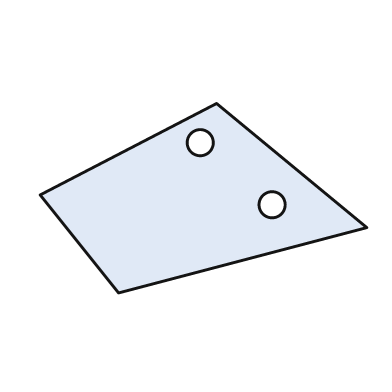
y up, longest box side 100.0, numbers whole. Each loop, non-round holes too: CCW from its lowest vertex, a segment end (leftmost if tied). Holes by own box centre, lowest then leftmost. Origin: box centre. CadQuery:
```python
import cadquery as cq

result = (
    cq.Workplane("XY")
    .moveTo(-26.0, -29.0)
    .lineTo(50.0, -9.0)
    .lineTo(4.0, 29.0)
    .lineTo(-50.0, 1.0)
    .close()
    .moveTo(21.0, -2.0)
    .circle(4.0)
    .moveTo(-1.0, 17.0)
    .circle(4.0)
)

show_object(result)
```